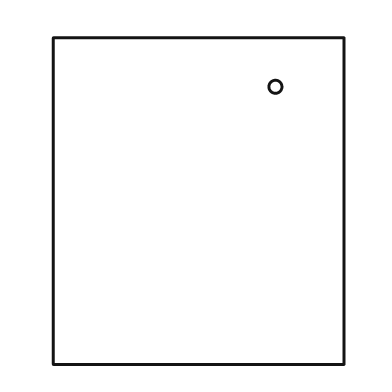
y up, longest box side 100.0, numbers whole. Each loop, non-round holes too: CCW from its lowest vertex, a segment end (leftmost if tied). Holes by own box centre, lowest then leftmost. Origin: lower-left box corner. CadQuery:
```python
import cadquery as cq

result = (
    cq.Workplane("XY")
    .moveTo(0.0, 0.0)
    .lineTo(89.0, 0.0)
    .lineTo(89.0, 100.0)
    .lineTo(0.0, 100.0)
    .close()
    .moveTo(68.0, 85.0)
    .circle(2.0)
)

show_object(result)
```